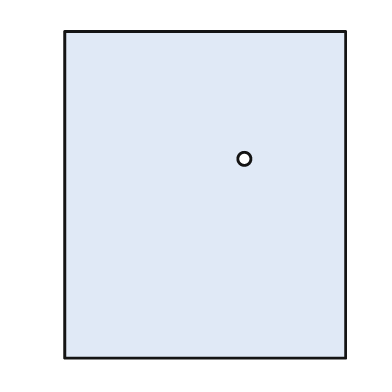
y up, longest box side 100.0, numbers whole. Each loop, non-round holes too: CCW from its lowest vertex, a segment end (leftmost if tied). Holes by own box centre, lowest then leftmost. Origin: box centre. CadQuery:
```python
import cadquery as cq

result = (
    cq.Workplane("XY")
    .moveTo(-43.0, -50.0)
    .lineTo(43.0, -50.0)
    .lineTo(43.0, 50.0)
    .lineTo(-43.0, 50.0)
    .close()
    .moveTo(12.0, 11.0)
    .circle(2.0)
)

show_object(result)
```